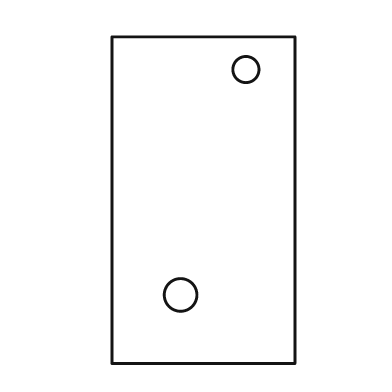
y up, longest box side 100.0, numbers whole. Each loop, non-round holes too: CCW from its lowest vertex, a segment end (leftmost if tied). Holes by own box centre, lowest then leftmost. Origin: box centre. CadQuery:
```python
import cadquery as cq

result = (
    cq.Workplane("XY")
    .moveTo(-28.0, -50.0)
    .lineTo(28.0, -50.0)
    .lineTo(28.0, 50.0)
    .lineTo(-28.0, 50.0)
    .close()
    .moveTo(-7.0, -29.0)
    .circle(5.0)
    .moveTo(13.0, 40.0)
    .circle(4.0)
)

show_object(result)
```